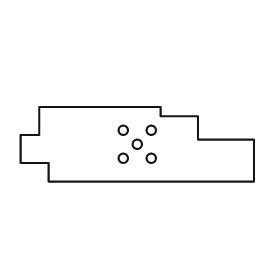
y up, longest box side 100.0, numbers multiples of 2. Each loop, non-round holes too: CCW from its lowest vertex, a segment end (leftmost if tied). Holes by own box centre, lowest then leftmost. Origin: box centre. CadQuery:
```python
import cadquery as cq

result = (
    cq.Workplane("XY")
    .moveTo(-38.0, -16.0)
    .lineTo(50.0, -16.0)
    .lineTo(50.0, 2.0)
    .lineTo(26.0, 2.0)
    .lineTo(26.0, 12.0)
    .lineTo(10.0, 12.0)
    .lineTo(10.0, 16.0)
    .lineTo(-42.0, 16.0)
    .lineTo(-42.0, 4.0)
    .lineTo(-50.0, 4.0)
    .lineTo(-50.0, -8.0)
    .lineTo(-38.0, -8.0)
    .close()
    .moveTo(-6.0, -6.0)
    .circle(2.0)
    .moveTo(6.0, -6.0)
    .circle(2.0)
    .moveTo(0.0, 0.0)
    .circle(2.0)
    .moveTo(-6.0, 6.0)
    .circle(2.0)
    .moveTo(6.0, 6.0)
    .circle(2.0)
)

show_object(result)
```